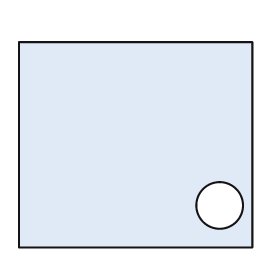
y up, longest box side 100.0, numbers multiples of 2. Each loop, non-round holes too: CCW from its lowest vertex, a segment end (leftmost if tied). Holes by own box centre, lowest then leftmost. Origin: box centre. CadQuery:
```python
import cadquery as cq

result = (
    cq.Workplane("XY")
    .moveTo(-50.0, -44.0)
    .lineTo(50.0, -44.0)
    .lineTo(50.0, 44.0)
    .lineTo(-50.0, 44.0)
    .close()
    .moveTo(36.0, -26.0)
    .circle(10.0)
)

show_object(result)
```